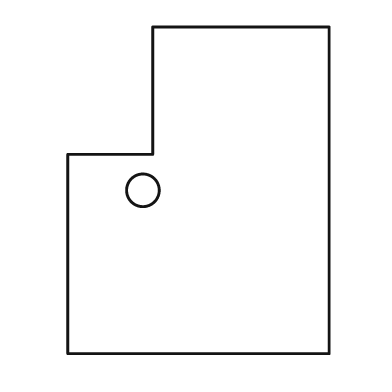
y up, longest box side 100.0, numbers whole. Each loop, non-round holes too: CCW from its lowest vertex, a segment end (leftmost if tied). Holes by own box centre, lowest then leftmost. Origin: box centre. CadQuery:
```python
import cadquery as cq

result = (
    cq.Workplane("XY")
    .moveTo(-40.0, -50.0)
    .lineTo(40.0, -50.0)
    .lineTo(40.0, 50.0)
    .lineTo(-14.0, 50.0)
    .lineTo(-14.0, 11.0)
    .lineTo(-40.0, 11.0)
    .close()
    .moveTo(-17.0, 0.0)
    .circle(5.0)
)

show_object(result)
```